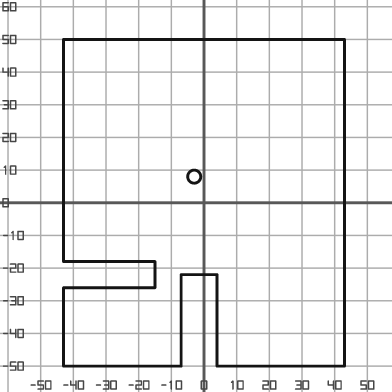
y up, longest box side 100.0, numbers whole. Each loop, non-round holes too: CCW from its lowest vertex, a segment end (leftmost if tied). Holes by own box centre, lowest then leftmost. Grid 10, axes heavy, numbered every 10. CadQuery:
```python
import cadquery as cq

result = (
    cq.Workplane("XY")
    .moveTo(-43.0, -50.0)
    .lineTo(-7.0, -50.0)
    .lineTo(-7.0, -22.0)
    .lineTo(4.0, -22.0)
    .lineTo(4.0, -50.0)
    .lineTo(43.0, -50.0)
    .lineTo(43.0, 50.0)
    .lineTo(-43.0, 50.0)
    .lineTo(-43.0, -18.0)
    .lineTo(-15.0, -18.0)
    .lineTo(-15.0, -26.0)
    .lineTo(-43.0, -26.0)
    .close()
    .moveTo(-3.0, 8.0)
    .circle(2.0)
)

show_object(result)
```